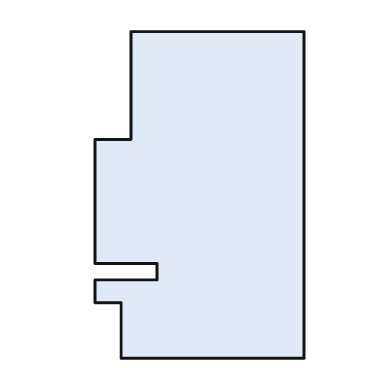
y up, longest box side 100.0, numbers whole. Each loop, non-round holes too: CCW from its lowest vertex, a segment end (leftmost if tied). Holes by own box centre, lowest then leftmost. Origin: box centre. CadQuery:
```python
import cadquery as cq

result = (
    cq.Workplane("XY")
    .moveTo(-24.0, -50.0)
    .lineTo(32.0, -50.0)
    .lineTo(32.0, 50.0)
    .lineTo(-21.0, 50.0)
    .lineTo(-21.0, 17.0)
    .lineTo(-32.0, 17.0)
    .lineTo(-32.0, -21.0)
    .lineTo(-13.0, -21.0)
    .lineTo(-13.0, -26.0)
    .lineTo(-32.0, -26.0)
    .lineTo(-32.0, -33.0)
    .lineTo(-24.0, -33.0)
    .close()
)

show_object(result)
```